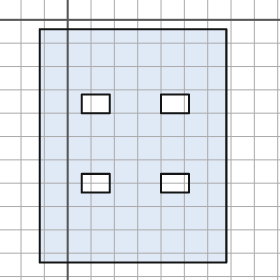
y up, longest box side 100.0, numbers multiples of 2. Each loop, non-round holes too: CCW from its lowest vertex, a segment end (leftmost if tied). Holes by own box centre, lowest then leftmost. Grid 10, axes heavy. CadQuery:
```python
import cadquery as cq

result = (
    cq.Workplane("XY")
    .moveTo(-12.0, -104.0)
    .lineTo(68.0, -104.0)
    .lineTo(68.0, -4.0)
    .lineTo(-12.0, -4.0)
    .close()
    .moveTo(6.0, -74.0)
    .lineTo(18.0, -74.0)
    .lineTo(18.0, -66.0)
    .lineTo(6.0, -66.0)
    .close()
    .moveTo(40.0, -74.0)
    .lineTo(52.0, -74.0)
    .lineTo(52.0, -66.0)
    .lineTo(40.0, -66.0)
    .close()
    .moveTo(6.0, -40.0)
    .lineTo(18.0, -40.0)
    .lineTo(18.0, -32.0)
    .lineTo(6.0, -32.0)
    .close()
    .moveTo(40.0, -40.0)
    .lineTo(52.0, -40.0)
    .lineTo(52.0, -32.0)
    .lineTo(40.0, -32.0)
    .close()
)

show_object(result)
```